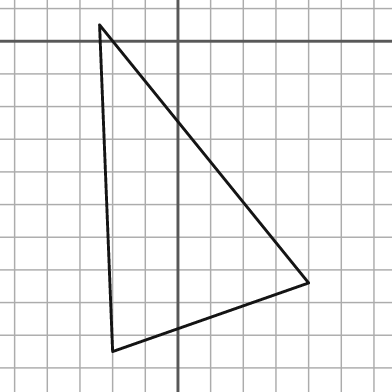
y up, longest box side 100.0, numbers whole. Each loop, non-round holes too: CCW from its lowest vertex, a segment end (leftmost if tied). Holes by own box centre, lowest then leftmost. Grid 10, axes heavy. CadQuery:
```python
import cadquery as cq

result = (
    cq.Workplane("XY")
    .moveTo(-20.0, -95.0)
    .lineTo(40.0, -74.0)
    .lineTo(-24.0, 5.0)
    .close()
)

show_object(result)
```